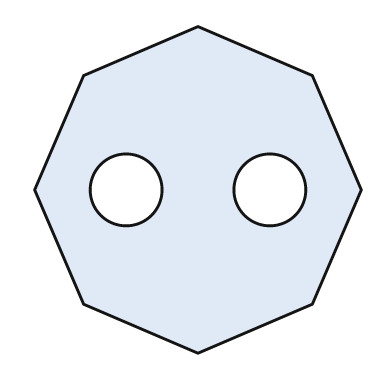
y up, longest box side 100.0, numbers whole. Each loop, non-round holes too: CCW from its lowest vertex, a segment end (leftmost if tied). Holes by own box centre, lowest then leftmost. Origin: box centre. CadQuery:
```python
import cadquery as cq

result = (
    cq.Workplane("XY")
    .moveTo(0.0, -50.0)
    .lineTo(35.0, -35.0)
    .lineTo(50.0, 0.0)
    .lineTo(35.0, 35.0)
    .lineTo(0.0, 50.0)
    .lineTo(-35.0, 35.0)
    .lineTo(-50.0, 0.0)
    .lineTo(-35.0, -35.0)
    .close()
    .moveTo(-22.0, 0.0)
    .circle(11.0)
    .moveTo(22.0, 0.0)
    .circle(11.0)
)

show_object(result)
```